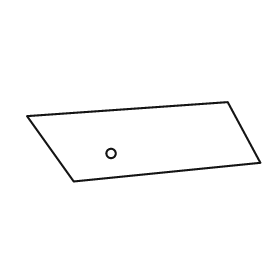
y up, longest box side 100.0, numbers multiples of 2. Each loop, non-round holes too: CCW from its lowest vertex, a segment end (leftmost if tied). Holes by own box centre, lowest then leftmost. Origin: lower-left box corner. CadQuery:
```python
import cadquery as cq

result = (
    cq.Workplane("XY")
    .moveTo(20.0, 0.0)
    .lineTo(100.0, 8.0)
    .lineTo(86.0, 34.0)
    .lineTo(0.0, 28.0)
    .close()
    .moveTo(36.0, 12.0)
    .circle(2.0)
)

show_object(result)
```